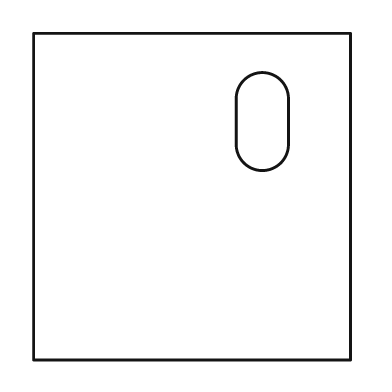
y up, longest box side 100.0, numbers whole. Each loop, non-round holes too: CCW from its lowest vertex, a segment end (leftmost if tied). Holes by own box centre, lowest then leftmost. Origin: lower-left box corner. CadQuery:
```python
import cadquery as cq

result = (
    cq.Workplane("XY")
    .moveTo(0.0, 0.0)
    .lineTo(97.0, 0.0)
    .lineTo(97.0, 100.0)
    .lineTo(0.0, 100.0)
    .close()
    .moveTo(62.0, 66.0)
    .threePointArc((70.0, 58.0), (78.0, 66.0))
    .lineTo(78.0, 80.0)
    .threePointArc((70.0, 88.0), (62.0, 80.0))
    .close()
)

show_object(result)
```